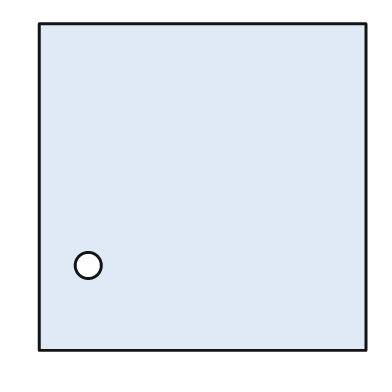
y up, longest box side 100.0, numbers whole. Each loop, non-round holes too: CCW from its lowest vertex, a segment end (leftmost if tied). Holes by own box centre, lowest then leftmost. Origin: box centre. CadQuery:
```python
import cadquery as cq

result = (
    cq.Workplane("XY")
    .moveTo(-50.0, -50.0)
    .lineTo(50.0, -50.0)
    .lineTo(50.0, 50.0)
    .lineTo(-50.0, 50.0)
    .close()
    .moveTo(-35.0, -24.0)
    .circle(4.0)
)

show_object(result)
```